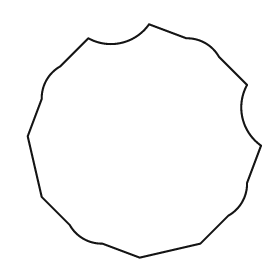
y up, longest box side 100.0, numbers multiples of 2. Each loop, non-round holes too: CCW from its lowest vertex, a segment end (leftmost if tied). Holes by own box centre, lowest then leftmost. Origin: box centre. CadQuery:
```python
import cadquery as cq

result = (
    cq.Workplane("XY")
    .moveTo(-2.0, -50.0)
    .lineTo(24.0, -44.0)
    .lineTo(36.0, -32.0)
    .threePointArc((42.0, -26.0), (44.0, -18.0))
    .lineTo(50.0, -2.0)
    .threePointArc((42.0, 10.0), (44.0, 24.0))
    .lineTo(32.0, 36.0)
    .threePointArc((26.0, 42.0), (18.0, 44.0))
    .lineTo(2.0, 50.0)
    .threePointArc((-10.0, 42.0), (-24.0, 44.0))
    .lineTo(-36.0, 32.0)
    .threePointArc((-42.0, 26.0), (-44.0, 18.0))
    .lineTo(-50.0, 2.0)
    .lineTo(-44.0, -24.0)
    .lineTo(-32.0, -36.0)
    .threePointArc((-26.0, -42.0), (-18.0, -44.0))
    .close()
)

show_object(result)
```